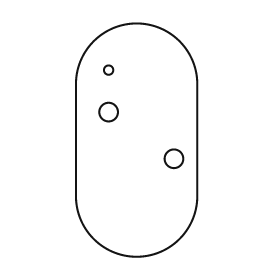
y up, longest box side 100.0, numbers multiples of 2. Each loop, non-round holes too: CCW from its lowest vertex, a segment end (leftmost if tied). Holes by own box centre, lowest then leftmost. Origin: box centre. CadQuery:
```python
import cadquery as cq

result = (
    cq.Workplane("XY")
    .moveTo(-26.0, -24.0)
    .threePointArc((0.0, -50.0), (26.0, -24.0))
    .lineTo(26.0, 24.0)
    .threePointArc((0.0, 50.0), (-26.0, 24.0))
    .close()
    .moveTo(16.0, -8.0)
    .circle(4.0)
    .moveTo(-12.0, 12.0)
    .circle(4.0)
    .moveTo(-12.0, 30.0)
    .circle(2.0)
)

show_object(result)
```